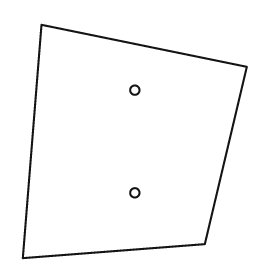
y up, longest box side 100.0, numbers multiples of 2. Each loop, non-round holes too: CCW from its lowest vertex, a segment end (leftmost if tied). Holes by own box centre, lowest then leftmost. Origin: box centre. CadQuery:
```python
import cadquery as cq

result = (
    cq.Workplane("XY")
    .moveTo(-48.0, -50.0)
    .lineTo(30.0, -44.0)
    .lineTo(48.0, 32.0)
    .lineTo(-40.0, 50.0)
    .close()
    .moveTo(0.0, -22.0)
    .circle(2.0)
    .moveTo(0.0, 22.0)
    .circle(2.0)
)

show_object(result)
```